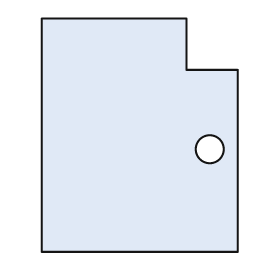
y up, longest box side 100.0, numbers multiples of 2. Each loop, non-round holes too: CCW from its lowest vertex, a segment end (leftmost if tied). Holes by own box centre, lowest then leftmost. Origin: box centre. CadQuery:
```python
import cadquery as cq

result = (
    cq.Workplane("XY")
    .moveTo(-42.0, -50.0)
    .lineTo(42.0, -50.0)
    .lineTo(42.0, 28.0)
    .lineTo(20.0, 28.0)
    .lineTo(20.0, 50.0)
    .lineTo(-42.0, 50.0)
    .close()
    .moveTo(30.0, -6.0)
    .circle(6.0)
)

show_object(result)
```